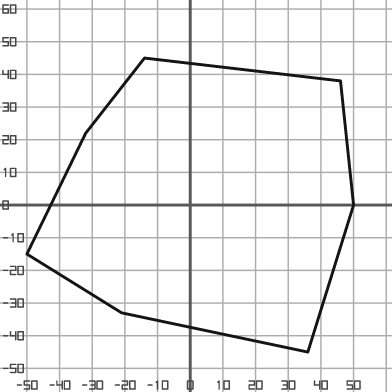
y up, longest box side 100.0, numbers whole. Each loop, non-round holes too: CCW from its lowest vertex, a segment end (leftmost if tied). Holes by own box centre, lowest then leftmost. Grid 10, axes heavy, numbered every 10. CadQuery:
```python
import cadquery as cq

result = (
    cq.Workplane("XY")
    .moveTo(36.0, -45.0)
    .lineTo(50.0, 0.0)
    .lineTo(46.0, 38.0)
    .lineTo(-14.0, 45.0)
    .lineTo(-32.0, 22.0)
    .lineTo(-50.0, -15.0)
    .lineTo(-21.0, -33.0)
    .close()
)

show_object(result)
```